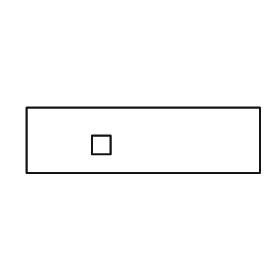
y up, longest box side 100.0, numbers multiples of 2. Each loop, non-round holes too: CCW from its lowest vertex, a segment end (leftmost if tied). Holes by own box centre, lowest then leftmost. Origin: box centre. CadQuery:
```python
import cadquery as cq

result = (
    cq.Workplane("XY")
    .moveTo(-50.0, -14.0)
    .lineTo(50.0, -14.0)
    .lineTo(50.0, 14.0)
    .lineTo(-50.0, 14.0)
    .close()
    .moveTo(-22.0, -6.0)
    .lineTo(-14.0, -6.0)
    .lineTo(-14.0, 2.0)
    .lineTo(-22.0, 2.0)
    .close()
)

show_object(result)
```